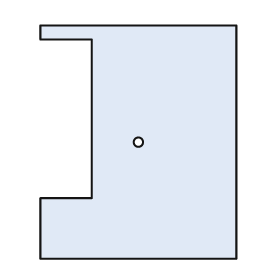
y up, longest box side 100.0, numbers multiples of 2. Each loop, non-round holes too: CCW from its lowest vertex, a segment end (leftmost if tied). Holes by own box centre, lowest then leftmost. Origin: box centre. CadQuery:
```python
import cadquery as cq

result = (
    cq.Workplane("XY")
    .moveTo(-42.0, -50.0)
    .lineTo(42.0, -50.0)
    .lineTo(42.0, 50.0)
    .lineTo(-42.0, 50.0)
    .lineTo(-42.0, 44.0)
    .lineTo(-20.0, 44.0)
    .lineTo(-20.0, -24.0)
    .lineTo(-42.0, -24.0)
    .close()
    .moveTo(0.0, 0.0)
    .circle(2.0)
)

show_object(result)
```